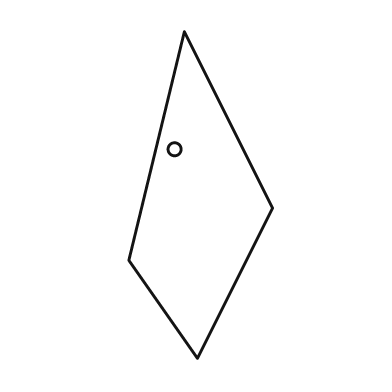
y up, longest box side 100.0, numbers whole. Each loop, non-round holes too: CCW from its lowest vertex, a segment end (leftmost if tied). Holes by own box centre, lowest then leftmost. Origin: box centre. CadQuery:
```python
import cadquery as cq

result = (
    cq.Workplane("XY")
    .moveTo(-1.0, -50.0)
    .lineTo(22.0, -4.0)
    .lineTo(-5.0, 50.0)
    .lineTo(-22.0, -20.0)
    .close()
    .moveTo(-8.0, 14.0)
    .circle(2.0)
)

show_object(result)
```